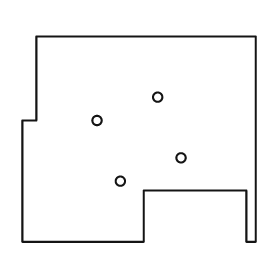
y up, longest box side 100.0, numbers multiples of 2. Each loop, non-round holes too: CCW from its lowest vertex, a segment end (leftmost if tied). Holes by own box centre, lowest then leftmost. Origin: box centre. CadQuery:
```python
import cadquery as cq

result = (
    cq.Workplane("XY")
    .moveTo(-50.0, -44.0)
    .lineTo(2.0, -44.0)
    .lineTo(2.0, -22.0)
    .lineTo(46.0, -22.0)
    .lineTo(46.0, -44.0)
    .lineTo(50.0, -44.0)
    .lineTo(50.0, 44.0)
    .lineTo(-44.0, 44.0)
    .lineTo(-44.0, 8.0)
    .lineTo(-50.0, 8.0)
    .close()
    .moveTo(-8.0, -18.0)
    .circle(2.0)
    .moveTo(18.0, -8.0)
    .circle(2.0)
    .moveTo(-18.0, 8.0)
    .circle(2.0)
    .moveTo(8.0, 18.0)
    .circle(2.0)
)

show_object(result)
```